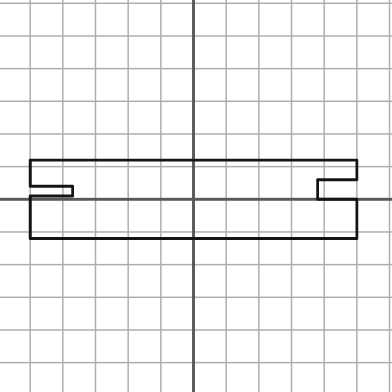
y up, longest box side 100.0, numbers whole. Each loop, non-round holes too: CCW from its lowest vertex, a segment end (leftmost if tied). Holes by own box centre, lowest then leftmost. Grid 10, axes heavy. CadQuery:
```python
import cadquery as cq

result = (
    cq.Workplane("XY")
    .moveTo(-50.0, -12.0)
    .lineTo(50.0, -12.0)
    .lineTo(50.0, 0.0)
    .lineTo(38.0, 0.0)
    .lineTo(38.0, 6.0)
    .lineTo(50.0, 6.0)
    .lineTo(50.0, 12.0)
    .lineTo(-50.0, 12.0)
    .lineTo(-50.0, 4.0)
    .lineTo(-37.0, 4.0)
    .lineTo(-37.0, 1.0)
    .lineTo(-50.0, 1.0)
    .close()
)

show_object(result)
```